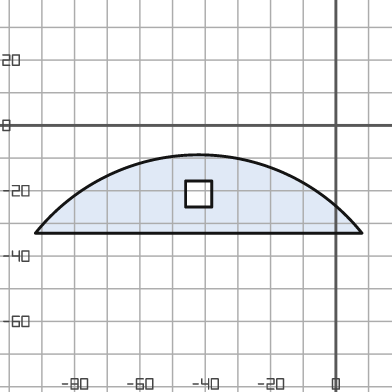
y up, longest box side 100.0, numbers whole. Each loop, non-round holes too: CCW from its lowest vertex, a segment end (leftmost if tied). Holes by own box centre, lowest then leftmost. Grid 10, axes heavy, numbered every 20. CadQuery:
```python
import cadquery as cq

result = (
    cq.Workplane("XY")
    .moveTo(-92.0, -33.0)
    .lineTo(8.0, -33.0)
    .threePointArc((-42.0, -9.0), (-92.0, -33.0))
    .close()
    .moveTo(-46.0, -25.0)
    .lineTo(-38.0, -25.0)
    .lineTo(-38.0, -17.0)
    .lineTo(-46.0, -17.0)
    .close()
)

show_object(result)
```